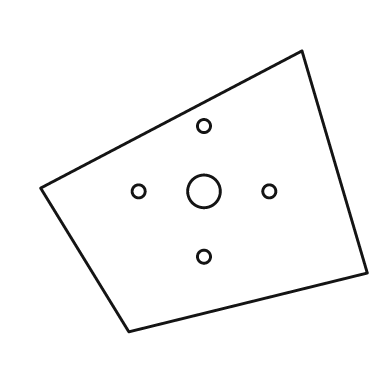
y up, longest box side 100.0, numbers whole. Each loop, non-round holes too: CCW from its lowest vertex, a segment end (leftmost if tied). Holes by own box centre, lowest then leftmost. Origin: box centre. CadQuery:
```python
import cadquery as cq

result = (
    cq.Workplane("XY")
    .moveTo(-23.0, -43.0)
    .lineTo(50.0, -25.0)
    .lineTo(30.0, 43.0)
    .lineTo(-50.0, 1.0)
    .close()
    .moveTo(0.0, -20.0)
    .circle(2.0)
    .moveTo(-20.0, 0.0)
    .circle(2.0)
    .moveTo(0.0, 0.0)
    .circle(5.0)
    .moveTo(20.0, 0.0)
    .circle(2.0)
    .moveTo(0.0, 20.0)
    .circle(2.0)
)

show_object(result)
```